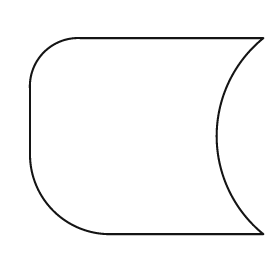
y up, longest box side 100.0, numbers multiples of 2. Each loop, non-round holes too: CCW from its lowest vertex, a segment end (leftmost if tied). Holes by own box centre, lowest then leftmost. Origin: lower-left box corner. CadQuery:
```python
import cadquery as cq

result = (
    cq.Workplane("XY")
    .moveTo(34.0, 0.0)
    .lineTo(100.0, 0.0)
    .threePointArc((80.0, 42.0), (100.0, 84.0))
    .lineTo(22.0, 84.0)
    .threePointArc((6.0, 78.0), (0.0, 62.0))
    .lineTo(0.0, 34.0)
    .threePointArc((10.0, 10.0), (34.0, 0.0))
    .close()
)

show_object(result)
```